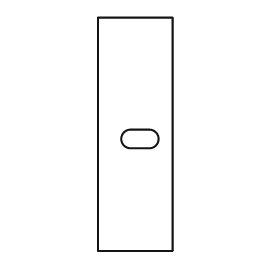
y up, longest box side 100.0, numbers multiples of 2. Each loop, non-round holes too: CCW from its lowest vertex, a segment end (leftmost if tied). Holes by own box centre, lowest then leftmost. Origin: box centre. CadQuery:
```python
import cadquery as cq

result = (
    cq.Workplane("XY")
    .moveTo(-16.0, -50.0)
    .lineTo(16.0, -50.0)
    .lineTo(16.0, 50.0)
    .lineTo(-16.0, 50.0)
    .close()
    .moveTo(-2.0, -6.0)
    .lineTo(6.0, -6.0)
    .threePointArc((10.0, -2.0), (6.0, 2.0))
    .lineTo(-2.0, 2.0)
    .threePointArc((-6.0, -2.0), (-2.0, -6.0))
    .close()
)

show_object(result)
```